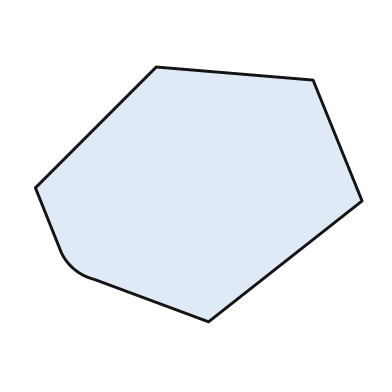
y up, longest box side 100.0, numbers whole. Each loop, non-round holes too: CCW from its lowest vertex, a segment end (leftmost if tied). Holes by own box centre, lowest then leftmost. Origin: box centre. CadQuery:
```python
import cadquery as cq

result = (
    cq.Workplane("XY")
    .moveTo(3.0, -39.0)
    .lineTo(50.0, -2.0)
    .lineTo(35.0, 35.0)
    .lineTo(-13.0, 39.0)
    .lineTo(-50.0, 2.0)
    .lineTo(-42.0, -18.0)
    .threePointArc((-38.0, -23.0), (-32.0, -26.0))
    .close()
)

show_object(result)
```